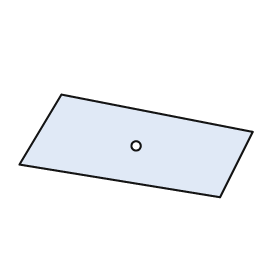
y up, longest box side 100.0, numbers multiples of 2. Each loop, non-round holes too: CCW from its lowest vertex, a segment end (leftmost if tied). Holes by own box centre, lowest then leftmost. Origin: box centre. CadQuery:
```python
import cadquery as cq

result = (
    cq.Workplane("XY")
    .moveTo(36.0, -22.0)
    .lineTo(50.0, 6.0)
    .lineTo(-32.0, 22.0)
    .lineTo(-50.0, -8.0)
    .close()
    .moveTo(0.0, 0.0)
    .circle(2.0)
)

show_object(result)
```